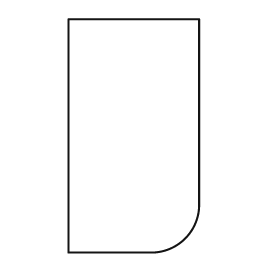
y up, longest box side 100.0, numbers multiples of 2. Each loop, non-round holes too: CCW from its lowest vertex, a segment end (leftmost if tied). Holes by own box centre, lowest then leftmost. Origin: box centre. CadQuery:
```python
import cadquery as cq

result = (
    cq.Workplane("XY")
    .moveTo(-28.0, -50.0)
    .lineTo(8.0, -50.0)
    .threePointArc((22.0, -44.0), (28.0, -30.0))
    .lineTo(28.0, 50.0)
    .lineTo(-28.0, 50.0)
    .close()
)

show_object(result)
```